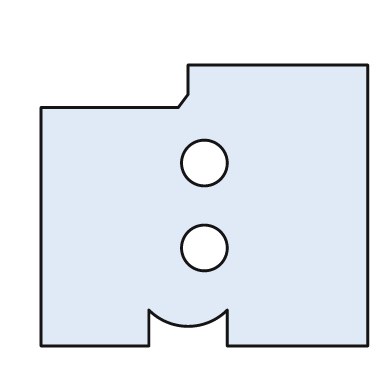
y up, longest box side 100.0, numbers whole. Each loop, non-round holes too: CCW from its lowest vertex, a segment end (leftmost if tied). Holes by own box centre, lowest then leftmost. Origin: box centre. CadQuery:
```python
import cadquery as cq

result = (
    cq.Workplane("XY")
    .moveTo(-50.0, -43.0)
    .lineTo(-17.0, -43.0)
    .lineTo(-17.0, -32.0)
    .threePointArc((-5.0, -37.0), (7.0, -32.0))
    .lineTo(7.0, -43.0)
    .lineTo(50.0, -43.0)
    .lineTo(50.0, 43.0)
    .lineTo(-5.0, 43.0)
    .lineTo(-5.0, 34.0)
    .lineTo(-8.0, 30.0)
    .lineTo(-50.0, 30.0)
    .close()
    .moveTo(0.0, -13.0)
    .circle(7.0)
    .moveTo(0.0, 13.0)
    .circle(7.0)
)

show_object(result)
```